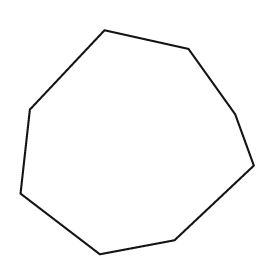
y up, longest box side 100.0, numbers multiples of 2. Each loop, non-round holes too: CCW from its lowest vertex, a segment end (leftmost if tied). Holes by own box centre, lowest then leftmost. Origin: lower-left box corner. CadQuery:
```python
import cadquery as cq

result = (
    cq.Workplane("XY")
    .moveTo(34.0, 0.0)
    .lineTo(66.0, 6.0)
    .lineTo(100.0, 38.0)
    .lineTo(92.0, 60.0)
    .lineTo(72.0, 88.0)
    .lineTo(36.0, 96.0)
    .lineTo(4.0, 62.0)
    .lineTo(0.0, 26.0)
    .close()
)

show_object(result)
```